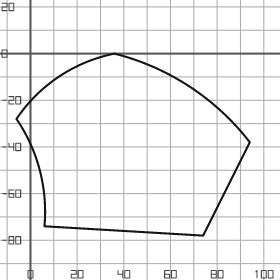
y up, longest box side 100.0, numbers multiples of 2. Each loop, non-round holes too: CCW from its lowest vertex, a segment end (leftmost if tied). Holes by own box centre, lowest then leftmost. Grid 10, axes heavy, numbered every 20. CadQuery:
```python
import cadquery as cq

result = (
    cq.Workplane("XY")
    .moveTo(74.0, -78.0)
    .lineTo(94.0, -38.0)
    .threePointArc((68.0, -14.0), (36.0, 0.0))
    .threePointArc((12.0, -10.0), (-6.0, -28.0))
    .threePointArc((4.0, -50.0), (6.0, -74.0))
    .close()
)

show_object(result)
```